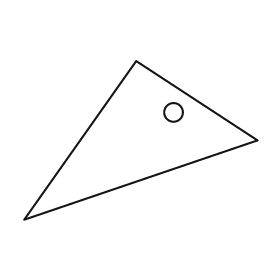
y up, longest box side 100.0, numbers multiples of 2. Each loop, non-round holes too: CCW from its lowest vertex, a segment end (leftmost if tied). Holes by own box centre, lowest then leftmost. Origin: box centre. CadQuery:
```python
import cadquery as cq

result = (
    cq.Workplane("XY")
    .moveTo(-50.0, -34.0)
    .lineTo(50.0, 0.0)
    .lineTo(-2.0, 34.0)
    .close()
    .moveTo(14.0, 12.0)
    .circle(4.0)
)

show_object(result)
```